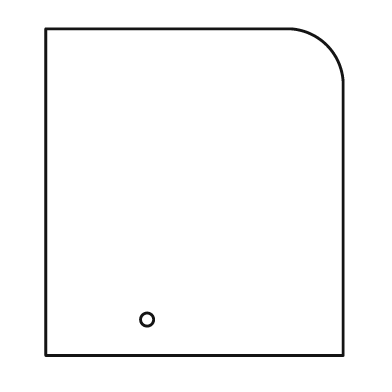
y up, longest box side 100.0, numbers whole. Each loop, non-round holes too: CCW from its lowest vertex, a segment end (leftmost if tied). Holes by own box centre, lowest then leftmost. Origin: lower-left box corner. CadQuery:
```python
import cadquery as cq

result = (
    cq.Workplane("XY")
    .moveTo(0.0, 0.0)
    .lineTo(91.0, 0.0)
    .lineTo(91.0, 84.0)
    .threePointArc((86.0, 95.0), (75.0, 100.0))
    .lineTo(0.0, 100.0)
    .close()
    .moveTo(31.0, 11.0)
    .circle(2.0)
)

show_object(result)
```